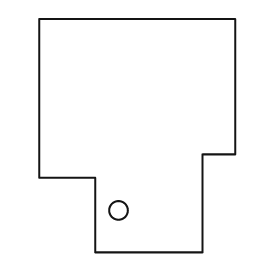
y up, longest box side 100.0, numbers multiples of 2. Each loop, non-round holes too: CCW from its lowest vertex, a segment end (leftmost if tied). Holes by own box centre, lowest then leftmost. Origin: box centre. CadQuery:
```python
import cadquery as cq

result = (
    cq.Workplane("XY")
    .moveTo(-18.0, -50.0)
    .lineTo(28.0, -50.0)
    .lineTo(28.0, -8.0)
    .lineTo(42.0, -8.0)
    .lineTo(42.0, 50.0)
    .lineTo(-42.0, 50.0)
    .lineTo(-42.0, -18.0)
    .lineTo(-18.0, -18.0)
    .close()
    .moveTo(-8.0, -32.0)
    .circle(4.0)
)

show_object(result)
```